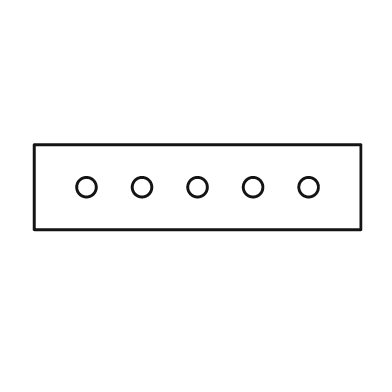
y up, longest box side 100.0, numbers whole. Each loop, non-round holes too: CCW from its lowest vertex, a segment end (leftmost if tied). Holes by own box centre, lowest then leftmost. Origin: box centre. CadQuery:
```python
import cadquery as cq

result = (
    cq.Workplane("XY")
    .moveTo(-50.0, -13.0)
    .lineTo(50.0, -13.0)
    .lineTo(50.0, 13.0)
    .lineTo(-50.0, 13.0)
    .close()
    .moveTo(-34.0, 0.0)
    .circle(3.0)
    .moveTo(-17.0, 0.0)
    .circle(3.0)
    .moveTo(0.0, 0.0)
    .circle(3.0)
    .moveTo(17.0, 0.0)
    .circle(3.0)
    .moveTo(34.0, 0.0)
    .circle(3.0)
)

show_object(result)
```